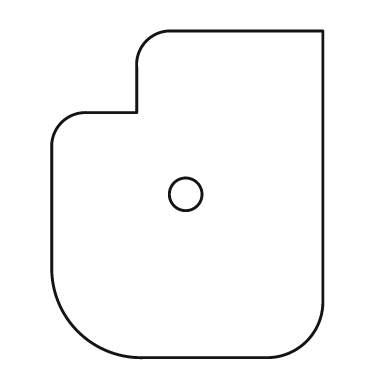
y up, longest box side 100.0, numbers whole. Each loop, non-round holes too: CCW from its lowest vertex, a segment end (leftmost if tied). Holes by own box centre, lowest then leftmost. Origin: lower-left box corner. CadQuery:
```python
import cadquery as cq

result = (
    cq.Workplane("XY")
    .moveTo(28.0, 0.0)
    .lineTo(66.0, 0.0)
    .threePointArc((78.0, 5.0), (83.0, 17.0))
    .lineTo(83.0, 100.0)
    .lineTo(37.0, 100.0)
    .threePointArc((29.0, 97.0), (26.0, 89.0))
    .lineTo(26.0, 75.0)
    .lineTo(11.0, 75.0)
    .threePointArc((3.0, 72.0), (0.0, 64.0))
    .lineTo(0.0, 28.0)
    .threePointArc((8.0, 8.0), (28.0, 0.0))
    .close()
    .moveTo(41.0, 50.0)
    .circle(5.0)
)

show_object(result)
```